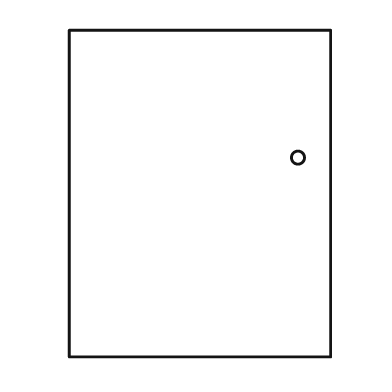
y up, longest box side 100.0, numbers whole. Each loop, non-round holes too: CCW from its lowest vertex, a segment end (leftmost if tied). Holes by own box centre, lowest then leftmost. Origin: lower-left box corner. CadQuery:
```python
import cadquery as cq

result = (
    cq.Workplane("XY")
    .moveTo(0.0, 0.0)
    .lineTo(80.0, 0.0)
    .lineTo(80.0, 100.0)
    .lineTo(0.0, 100.0)
    .close()
    .moveTo(70.0, 61.0)
    .circle(2.0)
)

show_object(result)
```